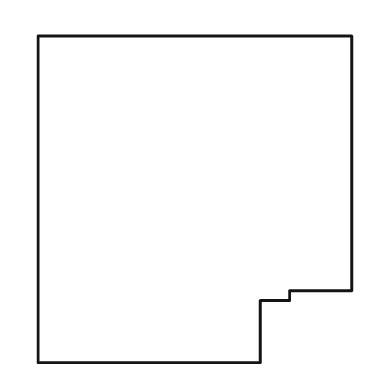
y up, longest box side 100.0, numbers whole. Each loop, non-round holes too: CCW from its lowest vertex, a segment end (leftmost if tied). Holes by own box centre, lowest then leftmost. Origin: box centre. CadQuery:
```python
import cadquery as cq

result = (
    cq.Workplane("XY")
    .moveTo(-48.0, -50.0)
    .lineTo(20.0, -50.0)
    .lineTo(20.0, -31.0)
    .lineTo(29.0, -31.0)
    .lineTo(29.0, -28.0)
    .lineTo(48.0, -28.0)
    .lineTo(48.0, 50.0)
    .lineTo(-48.0, 50.0)
    .close()
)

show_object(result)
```